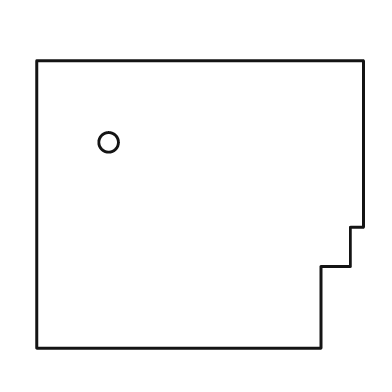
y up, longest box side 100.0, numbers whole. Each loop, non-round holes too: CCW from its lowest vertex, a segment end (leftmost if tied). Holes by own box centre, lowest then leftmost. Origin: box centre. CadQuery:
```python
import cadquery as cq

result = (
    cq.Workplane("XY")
    .moveTo(-50.0, -44.0)
    .lineTo(37.0, -44.0)
    .lineTo(37.0, -19.0)
    .lineTo(46.0, -19.0)
    .lineTo(46.0, -7.0)
    .lineTo(50.0, -7.0)
    .lineTo(50.0, 44.0)
    .lineTo(-50.0, 44.0)
    .close()
    .moveTo(-28.0, 19.0)
    .circle(3.0)
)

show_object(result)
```